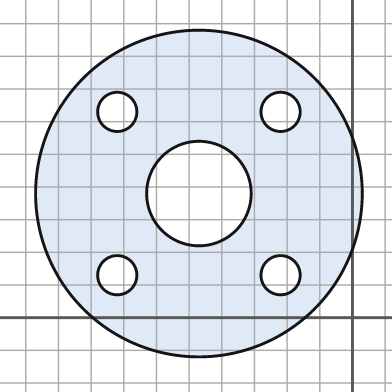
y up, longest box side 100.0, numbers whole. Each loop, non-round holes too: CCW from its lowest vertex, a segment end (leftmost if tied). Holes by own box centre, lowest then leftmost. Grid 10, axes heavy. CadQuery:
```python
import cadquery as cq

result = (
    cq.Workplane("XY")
    .moveTo(-47.0, 38.0)
    .circle(50.0)
    .moveTo(-72.0, 13.0)
    .circle(6.0)
    .moveTo(-22.0, 13.0)
    .circle(6.0)
    .moveTo(-47.0, 38.0)
    .circle(16.0)
    .moveTo(-72.0, 63.0)
    .circle(6.0)
    .moveTo(-22.0, 63.0)
    .circle(6.0)
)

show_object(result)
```